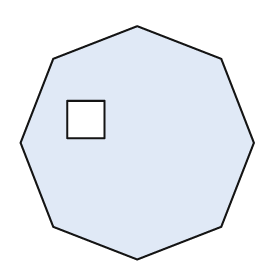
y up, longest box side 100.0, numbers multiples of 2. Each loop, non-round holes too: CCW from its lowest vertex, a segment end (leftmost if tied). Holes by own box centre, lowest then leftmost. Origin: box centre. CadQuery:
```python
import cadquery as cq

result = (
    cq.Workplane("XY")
    .moveTo(0.0, -50.0)
    .lineTo(36.0, -36.0)
    .lineTo(50.0, 0.0)
    .lineTo(36.0, 36.0)
    .lineTo(0.0, 50.0)
    .lineTo(-36.0, 36.0)
    .lineTo(-50.0, 0.0)
    .lineTo(-36.0, -36.0)
    .close()
    .moveTo(-30.0, 2.0)
    .lineTo(-14.0, 2.0)
    .lineTo(-14.0, 18.0)
    .lineTo(-30.0, 18.0)
    .close()
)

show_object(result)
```